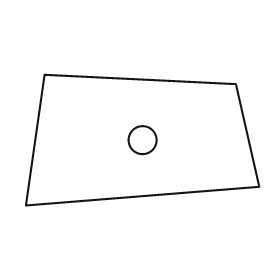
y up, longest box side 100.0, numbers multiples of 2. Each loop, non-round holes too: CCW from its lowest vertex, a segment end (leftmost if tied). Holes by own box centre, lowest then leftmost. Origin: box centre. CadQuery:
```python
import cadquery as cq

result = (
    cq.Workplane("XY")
    .moveTo(-50.0, -28.0)
    .lineTo(50.0, -20.0)
    .lineTo(40.0, 24.0)
    .lineTo(-42.0, 28.0)
    .close()
    .moveTo(0.0, 0.0)
    .circle(6.0)
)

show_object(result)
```